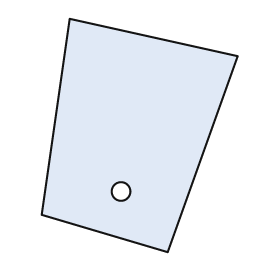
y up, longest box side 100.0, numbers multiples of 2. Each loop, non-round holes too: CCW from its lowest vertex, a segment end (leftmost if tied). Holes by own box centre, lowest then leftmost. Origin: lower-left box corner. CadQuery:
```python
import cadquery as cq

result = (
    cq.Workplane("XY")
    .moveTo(54.0, 0.0)
    .lineTo(84.0, 84.0)
    .lineTo(12.0, 100.0)
    .lineTo(0.0, 16.0)
    .close()
    .moveTo(34.0, 26.0)
    .circle(4.0)
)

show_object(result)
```